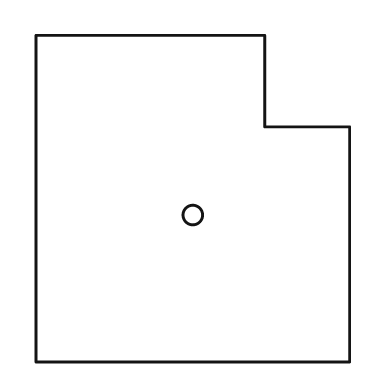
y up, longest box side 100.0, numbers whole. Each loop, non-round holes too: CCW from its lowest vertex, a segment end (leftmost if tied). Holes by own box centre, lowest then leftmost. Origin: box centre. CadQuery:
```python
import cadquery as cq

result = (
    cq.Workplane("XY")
    .moveTo(-48.0, -50.0)
    .lineTo(48.0, -50.0)
    .lineTo(48.0, 22.0)
    .lineTo(22.0, 22.0)
    .lineTo(22.0, 50.0)
    .lineTo(-48.0, 50.0)
    .close()
    .moveTo(0.0, -5.0)
    .circle(3.0)
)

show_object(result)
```